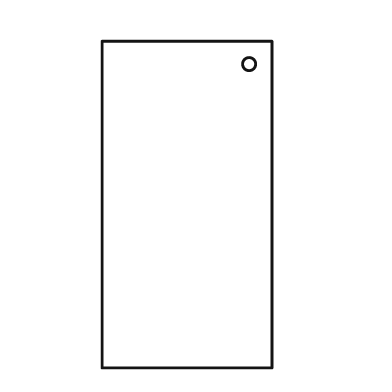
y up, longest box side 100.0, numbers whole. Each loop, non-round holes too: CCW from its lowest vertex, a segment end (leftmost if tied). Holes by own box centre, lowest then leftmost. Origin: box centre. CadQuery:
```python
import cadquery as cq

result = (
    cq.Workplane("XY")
    .moveTo(-26.0, -50.0)
    .lineTo(26.0, -50.0)
    .lineTo(26.0, 50.0)
    .lineTo(-26.0, 50.0)
    .close()
    .moveTo(19.0, 43.0)
    .circle(2.0)
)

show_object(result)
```